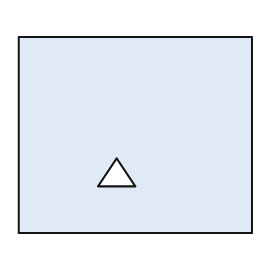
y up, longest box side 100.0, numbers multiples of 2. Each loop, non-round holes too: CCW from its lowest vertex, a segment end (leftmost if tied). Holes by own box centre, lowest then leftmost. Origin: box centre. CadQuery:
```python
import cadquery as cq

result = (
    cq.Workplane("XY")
    .moveTo(-50.0, -42.0)
    .lineTo(50.0, -42.0)
    .lineTo(50.0, 42.0)
    .lineTo(-50.0, 42.0)
    .close()
    .moveTo(-16.0, -22.0)
    .lineTo(0.0, -22.0)
    .lineTo(-8.0, -10.0)
    .close()
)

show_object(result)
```